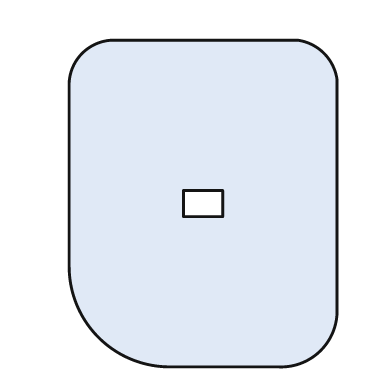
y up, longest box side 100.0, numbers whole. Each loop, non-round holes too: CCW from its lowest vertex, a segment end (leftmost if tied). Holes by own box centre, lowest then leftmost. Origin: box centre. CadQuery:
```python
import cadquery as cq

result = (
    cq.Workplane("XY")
    .moveTo(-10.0, -50.0)
    .lineTo(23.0, -50.0)
    .threePointArc((36.0, -45.0), (41.0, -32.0))
    .lineTo(41.0, 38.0)
    .threePointArc((37.0, 46.0), (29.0, 50.0))
    .lineTo(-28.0, 50.0)
    .threePointArc((-37.0, 46.0), (-41.0, 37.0))
    .lineTo(-41.0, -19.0)
    .threePointArc((-32.0, -41.0), (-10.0, -50.0))
    .close()
    .moveTo(-6.0, -4.0)
    .lineTo(6.0, -4.0)
    .lineTo(6.0, 4.0)
    .lineTo(-6.0, 4.0)
    .close()
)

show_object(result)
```